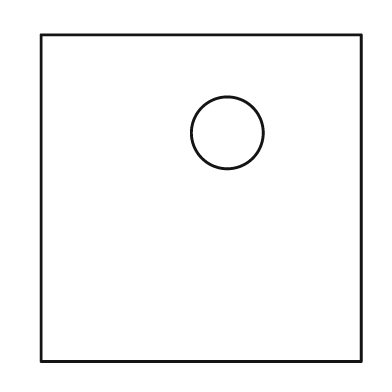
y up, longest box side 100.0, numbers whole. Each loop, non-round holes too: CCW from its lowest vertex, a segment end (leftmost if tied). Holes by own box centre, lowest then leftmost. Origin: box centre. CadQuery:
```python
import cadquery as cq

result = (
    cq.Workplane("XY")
    .moveTo(-49.0, -50.0)
    .lineTo(49.0, -50.0)
    .lineTo(49.0, 50.0)
    .lineTo(-49.0, 50.0)
    .close()
    .moveTo(8.0, 20.0)
    .circle(11.0)
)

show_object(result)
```